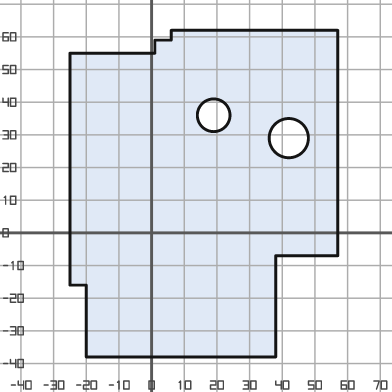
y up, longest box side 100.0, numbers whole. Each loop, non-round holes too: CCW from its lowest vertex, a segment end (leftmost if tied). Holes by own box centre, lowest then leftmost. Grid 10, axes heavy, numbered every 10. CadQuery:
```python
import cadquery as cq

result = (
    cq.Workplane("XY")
    .moveTo(-20.0, -38.0)
    .lineTo(38.0, -38.0)
    .lineTo(38.0, -7.0)
    .lineTo(57.0, -7.0)
    .lineTo(57.0, 62.0)
    .lineTo(6.0, 62.0)
    .lineTo(6.0, 59.0)
    .lineTo(1.0, 59.0)
    .lineTo(1.0, 55.0)
    .lineTo(-25.0, 55.0)
    .lineTo(-25.0, -16.0)
    .lineTo(-20.0, -16.0)
    .close()
    .moveTo(42.0, 29.0)
    .circle(6.0)
    .moveTo(19.0, 36.0)
    .circle(5.0)
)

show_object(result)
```